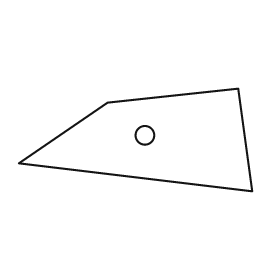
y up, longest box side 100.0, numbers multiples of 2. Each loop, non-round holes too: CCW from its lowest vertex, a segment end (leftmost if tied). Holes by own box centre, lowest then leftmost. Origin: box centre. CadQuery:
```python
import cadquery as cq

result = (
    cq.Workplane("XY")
    .moveTo(50.0, -22.0)
    .lineTo(44.0, 22.0)
    .lineTo(-12.0, 16.0)
    .lineTo(-50.0, -10.0)
    .close()
    .moveTo(4.0, 2.0)
    .circle(4.0)
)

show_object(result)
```